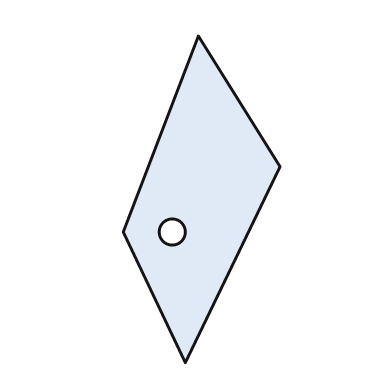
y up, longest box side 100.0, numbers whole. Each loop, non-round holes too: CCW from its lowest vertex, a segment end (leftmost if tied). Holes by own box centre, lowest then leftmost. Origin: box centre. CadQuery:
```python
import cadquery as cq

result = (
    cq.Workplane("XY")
    .moveTo(-5.0, -50.0)
    .lineTo(24.0, 10.0)
    .lineTo(-1.0, 50.0)
    .lineTo(-24.0, -10.0)
    .close()
    .moveTo(-9.0, -10.0)
    .circle(4.0)
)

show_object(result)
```